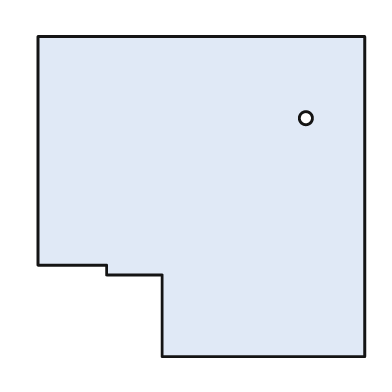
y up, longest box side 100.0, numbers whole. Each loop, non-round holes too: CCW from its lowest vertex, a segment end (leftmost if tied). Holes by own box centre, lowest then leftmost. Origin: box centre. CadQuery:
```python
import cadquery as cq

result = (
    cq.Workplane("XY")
    .moveTo(-12.0, -49.0)
    .lineTo(50.0, -49.0)
    .lineTo(50.0, 49.0)
    .lineTo(-50.0, 49.0)
    .lineTo(-50.0, -21.0)
    .lineTo(-29.0, -21.0)
    .lineTo(-29.0, -24.0)
    .lineTo(-12.0, -24.0)
    .close()
    .moveTo(32.0, 24.0)
    .circle(2.0)
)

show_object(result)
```